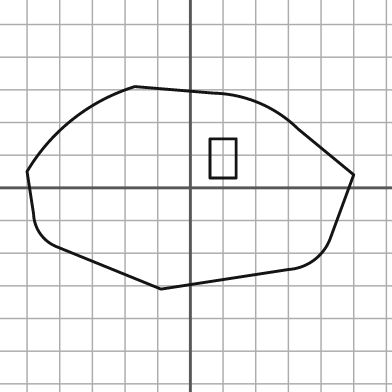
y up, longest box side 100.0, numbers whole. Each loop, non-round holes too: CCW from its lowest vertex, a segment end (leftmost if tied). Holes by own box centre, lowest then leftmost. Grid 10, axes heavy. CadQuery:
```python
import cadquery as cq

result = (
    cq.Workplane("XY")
    .moveTo(-9.0, -31.0)
    .lineTo(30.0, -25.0)
    .threePointArc((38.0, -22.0), (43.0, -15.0))
    .lineTo(50.0, 4.0)
    .lineTo(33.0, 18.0)
    .threePointArc((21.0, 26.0), (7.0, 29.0))
    .lineTo(-17.0, 31.0)
    .threePointArc((-36.0, 21.0), (-50.0, 5.0))
    .lineTo(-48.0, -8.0)
    .threePointArc((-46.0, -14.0), (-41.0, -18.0))
    .close()
    .moveTo(6.0, 3.0)
    .lineTo(14.0, 3.0)
    .lineTo(14.0, 15.0)
    .lineTo(6.0, 15.0)
    .close()
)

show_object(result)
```